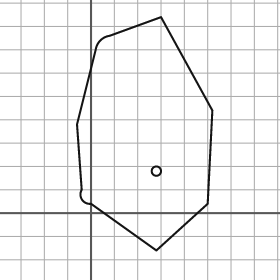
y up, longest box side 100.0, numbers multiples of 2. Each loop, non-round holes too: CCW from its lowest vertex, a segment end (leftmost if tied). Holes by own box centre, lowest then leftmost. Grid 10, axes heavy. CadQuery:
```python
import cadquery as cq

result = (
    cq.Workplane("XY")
    .moveTo(28.0, -16.0)
    .lineTo(50.0, 4.0)
    .lineTo(52.0, 44.0)
    .lineTo(30.0, 84.0)
    .lineTo(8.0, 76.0)
    .threePointArc((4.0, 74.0), (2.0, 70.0))
    .lineTo(-6.0, 38.0)
    .lineTo(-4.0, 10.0)
    .threePointArc((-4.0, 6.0), (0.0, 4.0))
    .close()
    .moveTo(28.0, 18.0)
    .circle(2.0)
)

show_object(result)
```